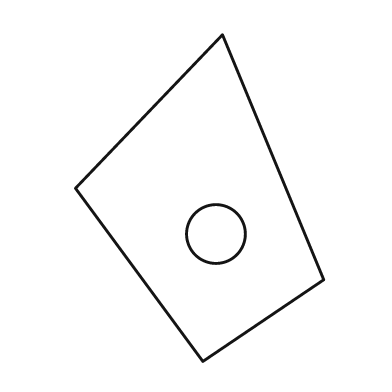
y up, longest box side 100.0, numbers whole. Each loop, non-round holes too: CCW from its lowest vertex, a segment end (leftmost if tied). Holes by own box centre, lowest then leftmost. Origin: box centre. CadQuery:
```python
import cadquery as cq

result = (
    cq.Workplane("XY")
    .moveTo(1.0, -50.0)
    .lineTo(38.0, -25.0)
    .lineTo(7.0, 50.0)
    .lineTo(-38.0, 3.0)
    .close()
    .moveTo(5.0, -11.0)
    .circle(9.0)
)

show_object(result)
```